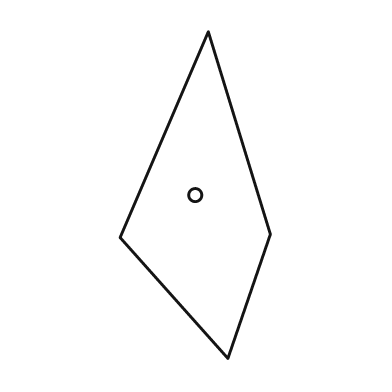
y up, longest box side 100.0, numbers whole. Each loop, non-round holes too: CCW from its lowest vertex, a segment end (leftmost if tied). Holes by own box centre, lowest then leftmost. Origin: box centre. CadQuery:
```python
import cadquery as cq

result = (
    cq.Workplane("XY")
    .moveTo(10.0, -50.0)
    .lineTo(23.0, -12.0)
    .lineTo(4.0, 50.0)
    .lineTo(-23.0, -13.0)
    .close()
    .moveTo(0.0, 0.0)
    .circle(2.0)
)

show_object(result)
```